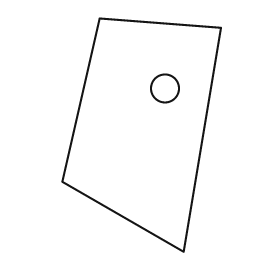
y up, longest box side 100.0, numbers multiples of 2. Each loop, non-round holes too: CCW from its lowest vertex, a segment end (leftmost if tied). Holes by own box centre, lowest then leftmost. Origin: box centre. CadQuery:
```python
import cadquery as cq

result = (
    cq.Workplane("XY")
    .moveTo(18.0, -50.0)
    .lineTo(34.0, 46.0)
    .lineTo(-18.0, 50.0)
    .lineTo(-34.0, -20.0)
    .close()
    .moveTo(10.0, 20.0)
    .circle(6.0)
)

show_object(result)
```